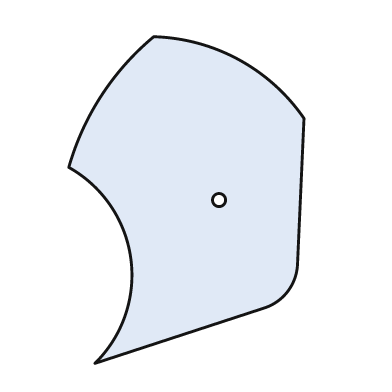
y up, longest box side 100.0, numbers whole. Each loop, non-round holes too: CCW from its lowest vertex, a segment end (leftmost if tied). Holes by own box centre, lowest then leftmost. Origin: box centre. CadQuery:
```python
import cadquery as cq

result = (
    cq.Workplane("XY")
    .moveTo(-28.0, -50.0)
    .lineTo(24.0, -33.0)
    .threePointArc((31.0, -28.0), (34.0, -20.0))
    .lineTo(36.0, 25.0)
    .threePointArc((16.0, 43.0), (-10.0, 50.0))
    .threePointArc((-26.0, 32.0), (-36.0, 10.0))
    .threePointArc((-17.0, -18.0), (-28.0, -50.0))
    .close()
    .moveTo(10.0, 0.0)
    .circle(2.0)
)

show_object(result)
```